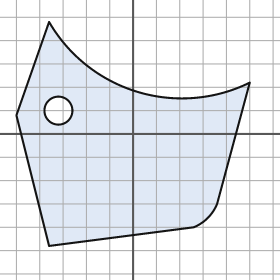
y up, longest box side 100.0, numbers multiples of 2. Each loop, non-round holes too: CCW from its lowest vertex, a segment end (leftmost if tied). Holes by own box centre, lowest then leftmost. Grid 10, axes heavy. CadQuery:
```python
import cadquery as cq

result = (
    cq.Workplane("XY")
    .moveTo(-36.0, -48.0)
    .lineTo(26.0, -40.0)
    .threePointArc((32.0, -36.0), (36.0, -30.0))
    .lineTo(50.0, 22.0)
    .threePointArc((2.0, 18.0), (-36.0, 48.0))
    .lineTo(-50.0, 8.0)
    .close()
    .moveTo(-32.0, 10.0)
    .circle(6.0)
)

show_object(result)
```